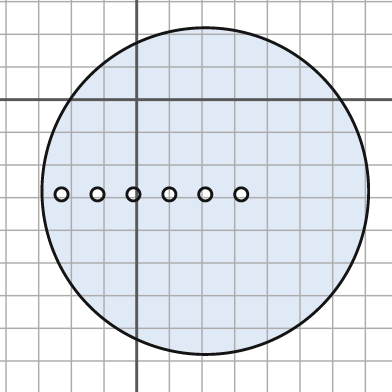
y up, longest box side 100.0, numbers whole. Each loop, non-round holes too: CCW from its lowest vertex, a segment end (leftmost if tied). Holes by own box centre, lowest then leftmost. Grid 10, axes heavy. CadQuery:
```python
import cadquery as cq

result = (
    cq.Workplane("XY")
    .moveTo(21.0, -28.0)
    .circle(50.0)
    .moveTo(-23.0, -29.0)
    .circle(2.0)
    .moveTo(-12.0, -29.0)
    .circle(2.0)
    .moveTo(-1.0, -29.0)
    .circle(2.0)
    .moveTo(10.0, -29.0)
    .circle(2.0)
    .moveTo(21.0, -29.0)
    .circle(2.0)
    .moveTo(32.0, -29.0)
    .circle(2.0)
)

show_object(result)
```